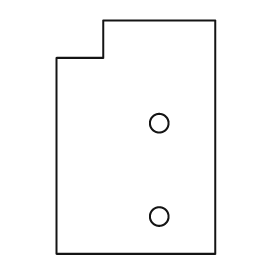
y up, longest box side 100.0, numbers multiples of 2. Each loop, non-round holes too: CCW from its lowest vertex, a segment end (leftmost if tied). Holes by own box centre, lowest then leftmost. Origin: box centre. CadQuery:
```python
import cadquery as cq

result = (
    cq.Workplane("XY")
    .moveTo(-34.0, -50.0)
    .lineTo(34.0, -50.0)
    .lineTo(34.0, 50.0)
    .lineTo(-14.0, 50.0)
    .lineTo(-14.0, 34.0)
    .lineTo(-34.0, 34.0)
    .close()
    .moveTo(10.0, -34.0)
    .circle(4.0)
    .moveTo(10.0, 6.0)
    .circle(4.0)
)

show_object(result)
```